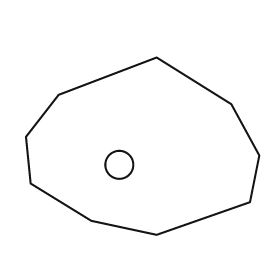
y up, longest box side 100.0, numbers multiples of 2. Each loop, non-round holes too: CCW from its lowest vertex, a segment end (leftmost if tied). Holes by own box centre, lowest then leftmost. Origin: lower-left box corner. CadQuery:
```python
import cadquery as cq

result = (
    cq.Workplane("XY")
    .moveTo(56.0, 0.0)
    .lineTo(96.0, 14.0)
    .lineTo(100.0, 34.0)
    .lineTo(88.0, 56.0)
    .lineTo(56.0, 76.0)
    .lineTo(14.0, 60.0)
    .lineTo(0.0, 42.0)
    .lineTo(2.0, 22.0)
    .lineTo(28.0, 6.0)
    .close()
    .moveTo(40.0, 30.0)
    .circle(6.0)
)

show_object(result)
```